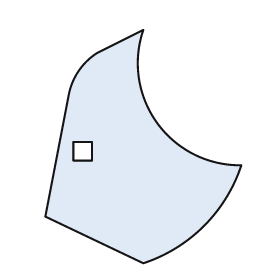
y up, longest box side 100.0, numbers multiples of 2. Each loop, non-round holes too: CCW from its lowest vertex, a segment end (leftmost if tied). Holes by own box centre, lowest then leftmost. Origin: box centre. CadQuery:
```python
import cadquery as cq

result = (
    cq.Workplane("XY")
    .moveTo(0.0, -50.0)
    .threePointArc((26.0, -34.0), (42.0, -8.0))
    .threePointArc((6.0, 10.0), (0.0, 50.0))
    .lineTo(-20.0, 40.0)
    .threePointArc((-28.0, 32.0), (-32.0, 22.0))
    .lineTo(-42.0, -30.0)
    .close()
    .moveTo(-30.0, -6.0)
    .lineTo(-22.0, -6.0)
    .lineTo(-22.0, 2.0)
    .lineTo(-30.0, 2.0)
    .close()
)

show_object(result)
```